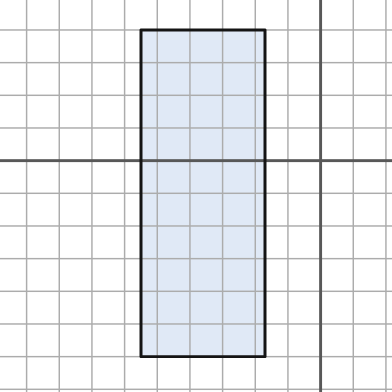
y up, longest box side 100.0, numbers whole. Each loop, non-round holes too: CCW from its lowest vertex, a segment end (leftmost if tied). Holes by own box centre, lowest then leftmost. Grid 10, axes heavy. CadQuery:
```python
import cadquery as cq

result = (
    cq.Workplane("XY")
    .moveTo(-55.0, -60.0)
    .lineTo(-17.0, -60.0)
    .lineTo(-17.0, 40.0)
    .lineTo(-55.0, 40.0)
    .close()
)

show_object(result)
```